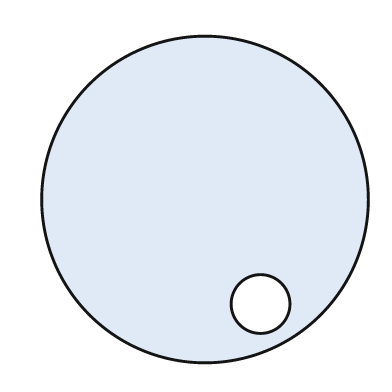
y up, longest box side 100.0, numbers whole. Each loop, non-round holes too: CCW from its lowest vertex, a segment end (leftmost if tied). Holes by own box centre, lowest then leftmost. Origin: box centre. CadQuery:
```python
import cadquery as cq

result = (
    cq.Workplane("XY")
    .moveTo(0.0, 0.0)
    .circle(50.0)
    .moveTo(17.0, -32.0)
    .circle(9.0)
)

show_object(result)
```